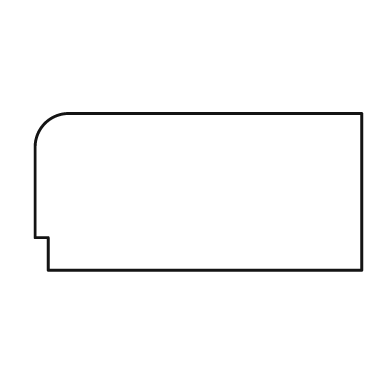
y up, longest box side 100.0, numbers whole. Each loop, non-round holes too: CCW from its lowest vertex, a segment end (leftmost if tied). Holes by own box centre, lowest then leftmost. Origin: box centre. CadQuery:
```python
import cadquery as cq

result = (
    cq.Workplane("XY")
    .moveTo(-46.0, -24.0)
    .lineTo(50.0, -24.0)
    .lineTo(50.0, 24.0)
    .lineTo(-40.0, 24.0)
    .threePointArc((-47.0, 21.0), (-50.0, 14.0))
    .lineTo(-50.0, -14.0)
    .lineTo(-46.0, -14.0)
    .close()
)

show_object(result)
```